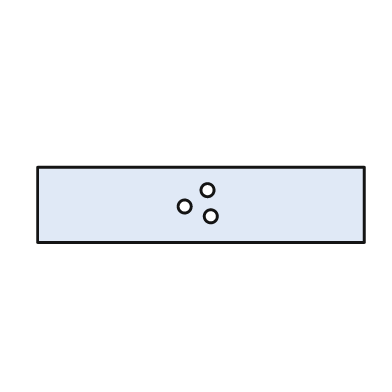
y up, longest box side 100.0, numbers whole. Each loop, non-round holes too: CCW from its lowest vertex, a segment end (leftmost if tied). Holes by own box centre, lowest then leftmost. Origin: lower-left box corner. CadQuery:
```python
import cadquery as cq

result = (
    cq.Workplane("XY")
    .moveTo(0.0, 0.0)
    .lineTo(100.0, 0.0)
    .lineTo(100.0, 23.0)
    .lineTo(0.0, 23.0)
    .close()
    .moveTo(53.0, 8.0)
    .circle(2.0)
    .moveTo(45.0, 11.0)
    .circle(2.0)
    .moveTo(52.0, 16.0)
    .circle(2.0)
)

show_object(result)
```